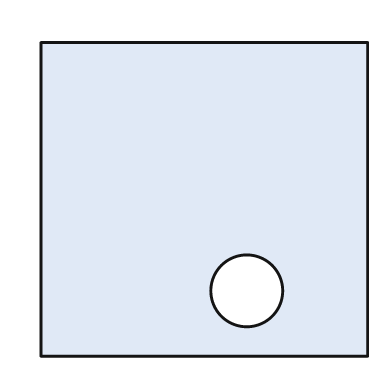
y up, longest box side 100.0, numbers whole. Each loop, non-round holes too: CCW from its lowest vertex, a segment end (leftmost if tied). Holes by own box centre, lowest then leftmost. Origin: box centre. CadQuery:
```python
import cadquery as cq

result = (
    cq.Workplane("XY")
    .moveTo(-50.0, -48.0)
    .lineTo(50.0, -48.0)
    .lineTo(50.0, 48.0)
    .lineTo(-50.0, 48.0)
    .close()
    .moveTo(13.0, -28.0)
    .circle(11.0)
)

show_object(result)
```